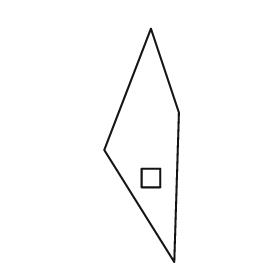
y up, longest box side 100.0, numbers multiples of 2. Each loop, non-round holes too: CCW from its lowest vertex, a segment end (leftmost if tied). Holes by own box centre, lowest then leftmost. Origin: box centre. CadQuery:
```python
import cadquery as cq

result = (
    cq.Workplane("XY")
    .moveTo(14.0, -50.0)
    .lineTo(16.0, 14.0)
    .lineTo(4.0, 50.0)
    .lineTo(-16.0, -2.0)
    .close()
    .moveTo(0.0, -18.0)
    .lineTo(8.0, -18.0)
    .lineTo(8.0, -10.0)
    .lineTo(0.0, -10.0)
    .close()
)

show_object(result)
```